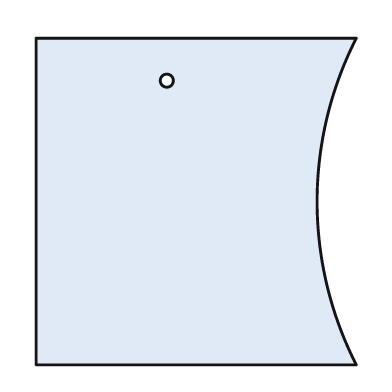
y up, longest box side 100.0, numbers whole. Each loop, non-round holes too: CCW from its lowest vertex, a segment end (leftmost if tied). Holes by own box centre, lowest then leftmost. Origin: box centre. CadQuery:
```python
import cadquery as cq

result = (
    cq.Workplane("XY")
    .moveTo(-49.0, -50.0)
    .lineTo(49.0, -50.0)
    .threePointArc((37.0, 0.0), (49.0, 50.0))
    .lineTo(-49.0, 50.0)
    .close()
    .moveTo(-9.0, 37.0)
    .circle(2.0)
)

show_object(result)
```